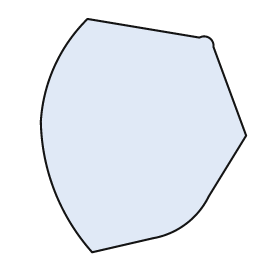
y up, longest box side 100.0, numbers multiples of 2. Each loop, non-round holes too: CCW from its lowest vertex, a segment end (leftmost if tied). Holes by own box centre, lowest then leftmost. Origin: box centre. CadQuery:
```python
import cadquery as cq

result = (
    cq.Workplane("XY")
    .moveTo(-22.0, -50.0)
    .lineTo(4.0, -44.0)
    .threePointArc((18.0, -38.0), (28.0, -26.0))
    .lineTo(44.0, 0.0)
    .lineTo(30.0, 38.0)
    .threePointArc((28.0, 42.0), (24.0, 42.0))
    .lineTo(-24.0, 50.0)
    .threePointArc((-38.0, 30.0), (-44.0, 6.0))
    .threePointArc((-38.0, -24.0), (-22.0, -50.0))
    .close()
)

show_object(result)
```